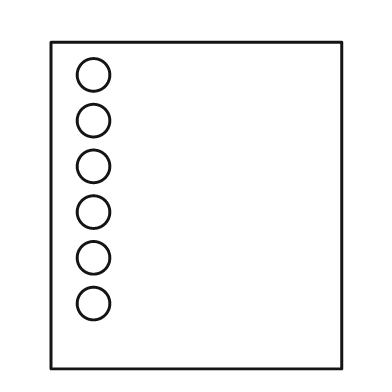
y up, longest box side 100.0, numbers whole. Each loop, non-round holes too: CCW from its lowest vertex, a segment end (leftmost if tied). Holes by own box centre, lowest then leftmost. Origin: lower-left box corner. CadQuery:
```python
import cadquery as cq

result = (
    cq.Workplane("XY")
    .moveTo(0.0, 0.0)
    .lineTo(89.0, 0.0)
    .lineTo(89.0, 100.0)
    .lineTo(0.0, 100.0)
    .close()
    .moveTo(13.0, 20.0)
    .circle(5.0)
    .moveTo(13.0, 34.0)
    .circle(5.0)
    .moveTo(13.0, 48.0)
    .circle(5.0)
    .moveTo(13.0, 62.0)
    .circle(5.0)
    .moveTo(13.0, 76.0)
    .circle(5.0)
    .moveTo(13.0, 90.0)
    .circle(5.0)
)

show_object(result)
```